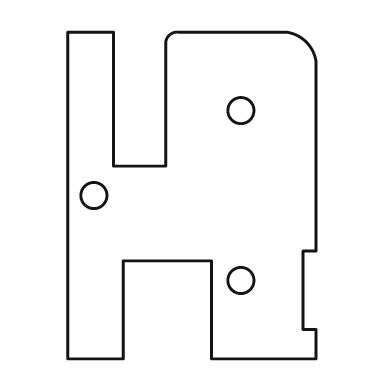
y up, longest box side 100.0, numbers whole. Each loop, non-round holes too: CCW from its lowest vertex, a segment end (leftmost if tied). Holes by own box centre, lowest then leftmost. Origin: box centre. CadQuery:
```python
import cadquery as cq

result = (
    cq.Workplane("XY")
    .moveTo(-38.0, -50.0)
    .lineTo(-21.0, -50.0)
    .lineTo(-21.0, -20.0)
    .lineTo(6.0, -20.0)
    .lineTo(6.0, -50.0)
    .lineTo(38.0, -50.0)
    .lineTo(38.0, -41.0)
    .lineTo(34.0, -41.0)
    .lineTo(34.0, -17.0)
    .lineTo(38.0, -17.0)
    .lineTo(38.0, 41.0)
    .threePointArc((35.0, 47.0), (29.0, 50.0))
    .lineTo(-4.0, 50.0)
    .threePointArc((-7.0, 49.0), (-8.0, 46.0))
    .lineTo(-8.0, 9.0)
    .lineTo(-24.0, 9.0)
    .lineTo(-24.0, 50.0)
    .lineTo(-38.0, 50.0)
    .close()
    .moveTo(15.0, -26.0)
    .circle(4.0)
    .moveTo(-30.0, 0.0)
    .circle(4.0)
    .moveTo(15.0, 26.0)
    .circle(4.0)
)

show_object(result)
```